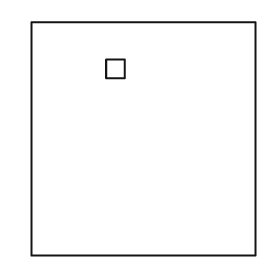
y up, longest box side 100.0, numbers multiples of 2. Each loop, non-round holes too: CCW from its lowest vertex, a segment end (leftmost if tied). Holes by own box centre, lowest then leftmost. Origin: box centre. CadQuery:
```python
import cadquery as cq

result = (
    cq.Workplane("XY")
    .moveTo(-48.0, -50.0)
    .lineTo(48.0, -50.0)
    .lineTo(48.0, 50.0)
    .lineTo(-48.0, 50.0)
    .close()
    .moveTo(-16.0, 26.0)
    .lineTo(-8.0, 26.0)
    .lineTo(-8.0, 34.0)
    .lineTo(-16.0, 34.0)
    .close()
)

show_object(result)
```